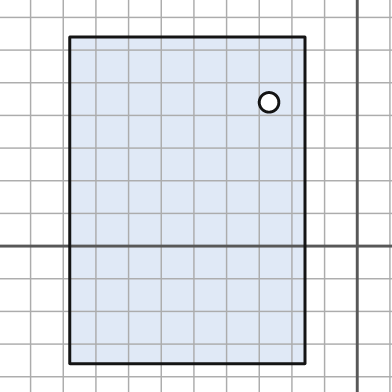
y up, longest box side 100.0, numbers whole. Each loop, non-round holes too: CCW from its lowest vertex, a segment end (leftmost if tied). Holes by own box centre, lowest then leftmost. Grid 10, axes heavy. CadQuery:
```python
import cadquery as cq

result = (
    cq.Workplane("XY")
    .moveTo(-88.0, -36.0)
    .lineTo(-16.0, -36.0)
    .lineTo(-16.0, 64.0)
    .lineTo(-88.0, 64.0)
    .close()
    .moveTo(-27.0, 44.0)
    .circle(3.0)
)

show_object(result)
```